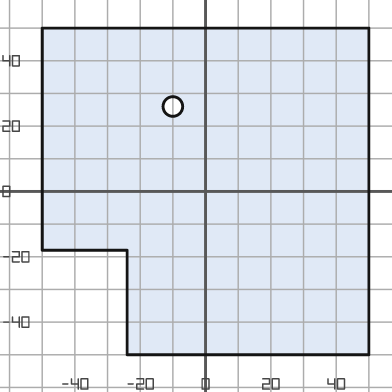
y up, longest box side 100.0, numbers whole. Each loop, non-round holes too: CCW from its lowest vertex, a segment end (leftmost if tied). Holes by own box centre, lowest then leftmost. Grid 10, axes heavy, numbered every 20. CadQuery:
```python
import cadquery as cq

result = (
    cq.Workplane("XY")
    .moveTo(-24.0, -50.0)
    .lineTo(50.0, -50.0)
    .lineTo(50.0, 50.0)
    .lineTo(-50.0, 50.0)
    .lineTo(-50.0, -18.0)
    .lineTo(-24.0, -18.0)
    .close()
    .moveTo(-10.0, 26.0)
    .circle(3.0)
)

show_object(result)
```